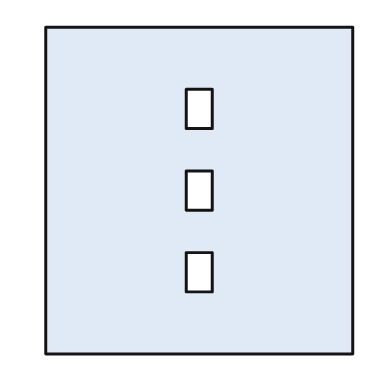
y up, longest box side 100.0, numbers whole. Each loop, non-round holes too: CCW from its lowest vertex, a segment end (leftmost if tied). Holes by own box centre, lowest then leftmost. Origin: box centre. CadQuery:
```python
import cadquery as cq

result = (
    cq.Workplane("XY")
    .moveTo(-47.0, -50.0)
    .lineTo(47.0, -50.0)
    .lineTo(47.0, 50.0)
    .lineTo(-47.0, 50.0)
    .close()
    .moveTo(-4.0, -31.0)
    .lineTo(4.0, -31.0)
    .lineTo(4.0, -19.0)
    .lineTo(-4.0, -19.0)
    .close()
    .moveTo(-4.0, -6.0)
    .lineTo(4.0, -6.0)
    .lineTo(4.0, 6.0)
    .lineTo(-4.0, 6.0)
    .close()
    .moveTo(-4.0, 19.0)
    .lineTo(4.0, 19.0)
    .lineTo(4.0, 31.0)
    .lineTo(-4.0, 31.0)
    .close()
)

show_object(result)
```